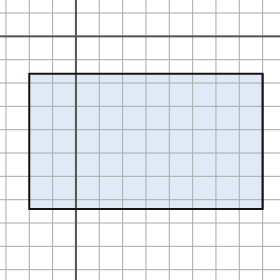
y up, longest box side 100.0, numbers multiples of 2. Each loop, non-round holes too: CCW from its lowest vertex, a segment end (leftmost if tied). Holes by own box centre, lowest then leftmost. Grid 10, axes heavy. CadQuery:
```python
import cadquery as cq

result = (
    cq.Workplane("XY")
    .moveTo(-20.0, -74.0)
    .lineTo(80.0, -74.0)
    .lineTo(80.0, -16.0)
    .lineTo(-20.0, -16.0)
    .close()
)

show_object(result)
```